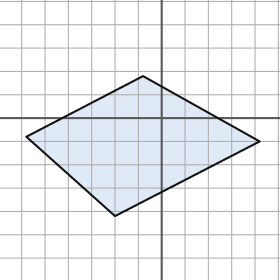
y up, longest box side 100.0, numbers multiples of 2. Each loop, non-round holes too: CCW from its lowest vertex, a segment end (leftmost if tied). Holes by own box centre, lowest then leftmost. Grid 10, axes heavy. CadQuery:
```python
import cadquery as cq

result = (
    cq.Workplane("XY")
    .moveTo(-20.0, -42.0)
    .lineTo(42.0, -10.0)
    .lineTo(-8.0, 18.0)
    .lineTo(-58.0, -8.0)
    .close()
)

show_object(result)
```